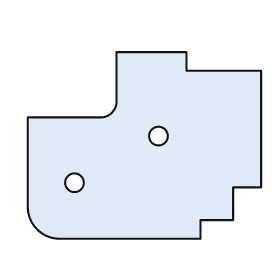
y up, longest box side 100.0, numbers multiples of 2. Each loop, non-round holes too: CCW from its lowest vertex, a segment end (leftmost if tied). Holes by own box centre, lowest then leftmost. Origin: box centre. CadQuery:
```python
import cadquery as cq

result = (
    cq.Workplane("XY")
    .moveTo(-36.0, -40.0)
    .lineTo(24.0, -40.0)
    .lineTo(24.0, -32.0)
    .lineTo(38.0, -32.0)
    .lineTo(38.0, -18.0)
    .lineTo(50.0, -18.0)
    .lineTo(50.0, 32.0)
    .lineTo(18.0, 32.0)
    .lineTo(18.0, 40.0)
    .lineTo(-12.0, 40.0)
    .lineTo(-12.0, 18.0)
    .threePointArc((-14.0, 14.0), (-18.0, 12.0))
    .lineTo(-50.0, 12.0)
    .lineTo(-50.0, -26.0)
    .threePointArc((-46.0, -36.0), (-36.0, -40.0))
    .close()
    .moveTo(-30.0, -16.0)
    .circle(4.0)
    .moveTo(6.0, 4.0)
    .circle(4.0)
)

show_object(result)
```